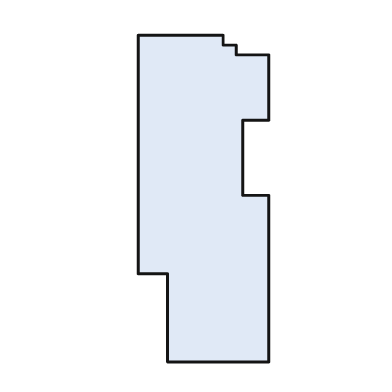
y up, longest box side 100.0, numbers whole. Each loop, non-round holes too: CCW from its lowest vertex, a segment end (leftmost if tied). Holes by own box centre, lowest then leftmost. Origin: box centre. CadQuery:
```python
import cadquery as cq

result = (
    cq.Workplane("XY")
    .moveTo(-11.0, -50.0)
    .lineTo(20.0, -50.0)
    .lineTo(20.0, 1.0)
    .lineTo(12.0, 1.0)
    .lineTo(12.0, 24.0)
    .lineTo(20.0, 24.0)
    .lineTo(20.0, 44.0)
    .lineTo(10.0, 44.0)
    .lineTo(10.0, 47.0)
    .lineTo(6.0, 47.0)
    .lineTo(6.0, 50.0)
    .lineTo(-20.0, 50.0)
    .lineTo(-20.0, -23.0)
    .lineTo(-11.0, -23.0)
    .close()
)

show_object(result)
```